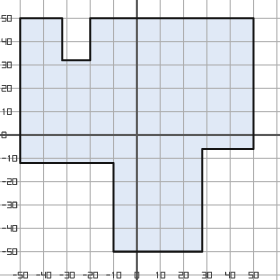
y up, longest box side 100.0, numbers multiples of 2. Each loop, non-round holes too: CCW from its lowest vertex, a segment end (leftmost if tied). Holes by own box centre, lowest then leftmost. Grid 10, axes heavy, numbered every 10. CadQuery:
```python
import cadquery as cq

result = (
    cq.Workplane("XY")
    .moveTo(-10.0, -50.0)
    .lineTo(28.0, -50.0)
    .lineTo(28.0, -6.0)
    .lineTo(50.0, -6.0)
    .lineTo(50.0, 50.0)
    .lineTo(-20.0, 50.0)
    .lineTo(-20.0, 32.0)
    .lineTo(-32.0, 32.0)
    .lineTo(-32.0, 50.0)
    .lineTo(-50.0, 50.0)
    .lineTo(-50.0, -12.0)
    .lineTo(-10.0, -12.0)
    .close()
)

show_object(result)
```